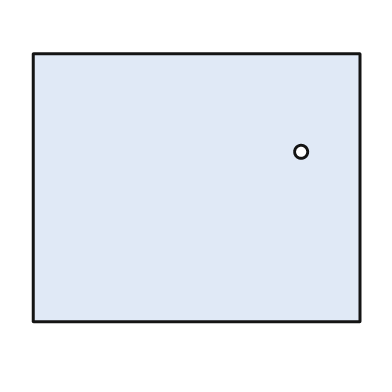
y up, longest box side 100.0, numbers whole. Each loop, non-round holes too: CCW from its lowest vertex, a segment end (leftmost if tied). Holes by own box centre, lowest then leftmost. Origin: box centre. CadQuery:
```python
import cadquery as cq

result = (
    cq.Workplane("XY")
    .moveTo(-50.0, -41.0)
    .lineTo(50.0, -41.0)
    .lineTo(50.0, 41.0)
    .lineTo(-50.0, 41.0)
    .close()
    .moveTo(32.0, 11.0)
    .circle(2.0)
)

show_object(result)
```